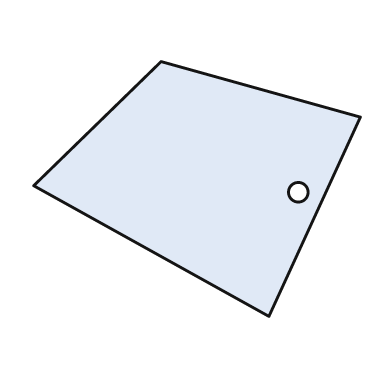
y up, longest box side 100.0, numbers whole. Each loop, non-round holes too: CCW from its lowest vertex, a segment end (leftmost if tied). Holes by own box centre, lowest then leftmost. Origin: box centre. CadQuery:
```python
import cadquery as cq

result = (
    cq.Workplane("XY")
    .moveTo(22.0, -39.0)
    .lineTo(50.0, 22.0)
    .lineTo(-11.0, 39.0)
    .lineTo(-50.0, 1.0)
    .close()
    .moveTo(31.0, -1.0)
    .circle(3.0)
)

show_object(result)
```